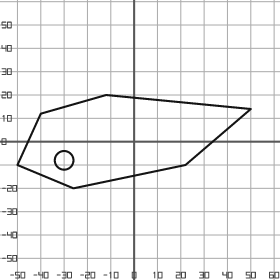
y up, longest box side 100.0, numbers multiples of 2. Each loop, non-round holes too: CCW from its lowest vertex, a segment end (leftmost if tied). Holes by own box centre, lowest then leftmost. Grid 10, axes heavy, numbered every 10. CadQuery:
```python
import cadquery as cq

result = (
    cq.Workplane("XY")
    .moveTo(-26.0, -20.0)
    .lineTo(22.0, -10.0)
    .lineTo(50.0, 14.0)
    .lineTo(-12.0, 20.0)
    .lineTo(-40.0, 12.0)
    .lineTo(-50.0, -10.0)
    .close()
    .moveTo(-30.0, -8.0)
    .circle(4.0)
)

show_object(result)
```